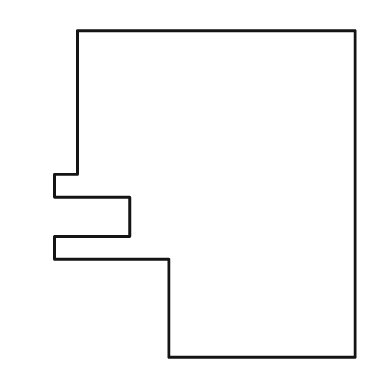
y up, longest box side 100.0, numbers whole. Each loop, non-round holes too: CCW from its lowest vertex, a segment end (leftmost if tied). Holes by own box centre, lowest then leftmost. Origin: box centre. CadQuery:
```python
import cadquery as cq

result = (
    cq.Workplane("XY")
    .moveTo(-11.0, -50.0)
    .lineTo(46.0, -50.0)
    .lineTo(46.0, 50.0)
    .lineTo(-39.0, 50.0)
    .lineTo(-39.0, 6.0)
    .lineTo(-46.0, 6.0)
    .lineTo(-46.0, -1.0)
    .lineTo(-23.0, -1.0)
    .lineTo(-23.0, -13.0)
    .lineTo(-46.0, -13.0)
    .lineTo(-46.0, -20.0)
    .lineTo(-11.0, -20.0)
    .close()
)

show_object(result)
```